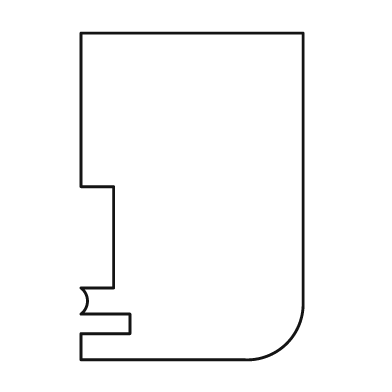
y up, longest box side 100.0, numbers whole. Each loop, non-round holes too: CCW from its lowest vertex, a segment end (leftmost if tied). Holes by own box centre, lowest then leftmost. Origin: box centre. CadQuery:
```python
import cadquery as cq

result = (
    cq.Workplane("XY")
    .moveTo(-34.0, -50.0)
    .lineTo(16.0, -50.0)
    .threePointArc((29.0, -45.0), (34.0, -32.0))
    .lineTo(34.0, 50.0)
    .lineTo(-34.0, 50.0)
    .lineTo(-34.0, 3.0)
    .lineTo(-24.0, 3.0)
    .lineTo(-24.0, -28.0)
    .lineTo(-34.0, -28.0)
    .threePointArc((-32.0, -32.0), (-34.0, -36.0))
    .lineTo(-19.0, -36.0)
    .lineTo(-19.0, -42.0)
    .lineTo(-34.0, -42.0)
    .close()
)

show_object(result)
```